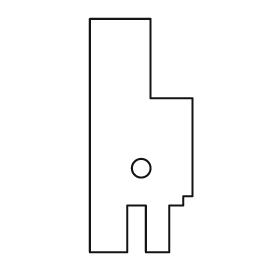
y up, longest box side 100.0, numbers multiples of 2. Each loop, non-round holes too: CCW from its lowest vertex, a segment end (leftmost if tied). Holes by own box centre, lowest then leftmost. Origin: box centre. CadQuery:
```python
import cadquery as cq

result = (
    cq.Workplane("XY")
    .moveTo(-22.0, -50.0)
    .lineTo(-6.0, -50.0)
    .lineTo(-6.0, -30.0)
    .lineTo(2.0, -30.0)
    .lineTo(2.0, -50.0)
    .lineTo(12.0, -50.0)
    .lineTo(12.0, -30.0)
    .lineTo(18.0, -30.0)
    .lineTo(18.0, -26.0)
    .lineTo(22.0, -26.0)
    .lineTo(22.0, 16.0)
    .lineTo(4.0, 16.0)
    .lineTo(4.0, 50.0)
    .lineTo(-22.0, 50.0)
    .close()
    .moveTo(0.0, -14.0)
    .circle(4.0)
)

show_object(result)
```